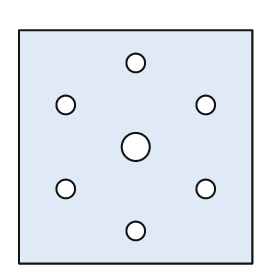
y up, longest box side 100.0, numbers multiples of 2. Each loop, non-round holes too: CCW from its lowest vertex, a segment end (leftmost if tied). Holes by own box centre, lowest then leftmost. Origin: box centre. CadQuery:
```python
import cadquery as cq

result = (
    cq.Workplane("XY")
    .moveTo(-50.0, -50.0)
    .lineTo(50.0, -50.0)
    .lineTo(50.0, 50.0)
    .lineTo(-50.0, 50.0)
    .close()
    .moveTo(0.0, -36.0)
    .circle(4.0)
    .moveTo(-30.0, -18.0)
    .circle(4.0)
    .moveTo(30.0, -18.0)
    .circle(4.0)
    .moveTo(0.0, 0.0)
    .circle(6.0)
    .moveTo(-30.0, 18.0)
    .circle(4.0)
    .moveTo(30.0, 18.0)
    .circle(4.0)
    .moveTo(0.0, 36.0)
    .circle(4.0)
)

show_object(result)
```